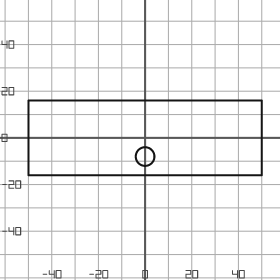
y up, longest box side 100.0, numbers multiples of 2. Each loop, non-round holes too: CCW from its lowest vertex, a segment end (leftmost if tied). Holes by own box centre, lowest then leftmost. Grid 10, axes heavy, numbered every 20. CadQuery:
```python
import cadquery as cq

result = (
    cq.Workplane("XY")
    .moveTo(-50.0, -16.0)
    .lineTo(50.0, -16.0)
    .lineTo(50.0, 16.0)
    .lineTo(-50.0, 16.0)
    .close()
    .moveTo(0.0, -8.0)
    .circle(4.0)
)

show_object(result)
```